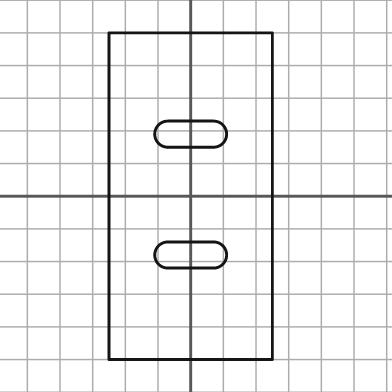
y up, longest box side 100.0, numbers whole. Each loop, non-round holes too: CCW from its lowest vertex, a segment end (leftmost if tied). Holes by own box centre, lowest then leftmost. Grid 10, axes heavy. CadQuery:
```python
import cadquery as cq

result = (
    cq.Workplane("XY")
    .moveTo(-25.0, -50.0)
    .lineTo(25.0, -50.0)
    .lineTo(25.0, 50.0)
    .lineTo(-25.0, 50.0)
    .close()
    .moveTo(-7.0, -22.0)
    .lineTo(7.0, -22.0)
    .threePointArc((11.0, -18.0), (7.0, -14.0))
    .lineTo(-7.0, -14.0)
    .threePointArc((-11.0, -18.0), (-7.0, -22.0))
    .close()
    .moveTo(-7.0, 15.0)
    .lineTo(7.0, 15.0)
    .threePointArc((11.0, 19.0), (7.0, 23.0))
    .lineTo(-7.0, 23.0)
    .threePointArc((-11.0, 19.0), (-7.0, 15.0))
    .close()
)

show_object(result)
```